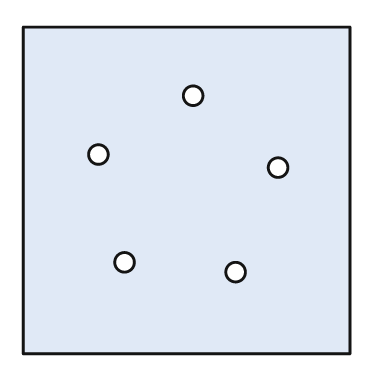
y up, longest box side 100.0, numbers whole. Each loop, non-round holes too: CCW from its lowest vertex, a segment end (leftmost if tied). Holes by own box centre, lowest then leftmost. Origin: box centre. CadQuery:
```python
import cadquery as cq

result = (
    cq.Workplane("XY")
    .moveTo(-50.0, -50.0)
    .lineTo(50.0, -50.0)
    .lineTo(50.0, 50.0)
    .lineTo(-50.0, 50.0)
    .close()
    .moveTo(15.0, -25.0)
    .circle(3.0)
    .moveTo(-19.0, -22.0)
    .circle(3.0)
    .moveTo(28.0, 7.0)
    .circle(3.0)
    .moveTo(-27.0, 11.0)
    .circle(3.0)
    .moveTo(2.0, 29.0)
    .circle(3.0)
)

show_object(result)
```